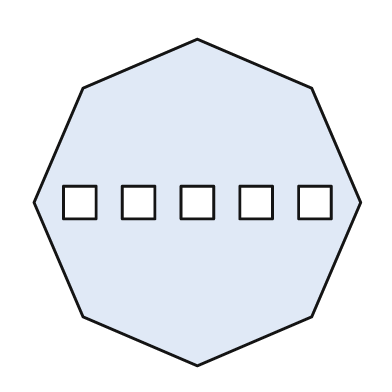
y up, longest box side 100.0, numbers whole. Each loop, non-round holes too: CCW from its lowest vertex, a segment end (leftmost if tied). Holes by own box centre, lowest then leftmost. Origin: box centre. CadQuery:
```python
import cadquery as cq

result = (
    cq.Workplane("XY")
    .moveTo(0.0, -50.0)
    .lineTo(35.0, -35.0)
    .lineTo(50.0, 0.0)
    .lineTo(35.0, 35.0)
    .lineTo(0.0, 50.0)
    .lineTo(-35.0, 35.0)
    .lineTo(-50.0, 0.0)
    .lineTo(-35.0, -35.0)
    .close()
    .moveTo(-41.0, -5.0)
    .lineTo(-31.0, -5.0)
    .lineTo(-31.0, 5.0)
    .lineTo(-41.0, 5.0)
    .close()
    .moveTo(-23.0, -5.0)
    .lineTo(-13.0, -5.0)
    .lineTo(-13.0, 5.0)
    .lineTo(-23.0, 5.0)
    .close()
    .moveTo(-5.0, -5.0)
    .lineTo(5.0, -5.0)
    .lineTo(5.0, 5.0)
    .lineTo(-5.0, 5.0)
    .close()
    .moveTo(13.0, -5.0)
    .lineTo(23.0, -5.0)
    .lineTo(23.0, 5.0)
    .lineTo(13.0, 5.0)
    .close()
    .moveTo(31.0, -5.0)
    .lineTo(41.0, -5.0)
    .lineTo(41.0, 5.0)
    .lineTo(31.0, 5.0)
    .close()
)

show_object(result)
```